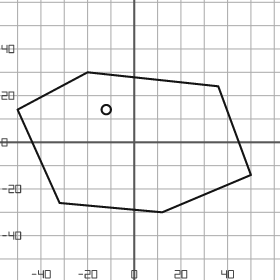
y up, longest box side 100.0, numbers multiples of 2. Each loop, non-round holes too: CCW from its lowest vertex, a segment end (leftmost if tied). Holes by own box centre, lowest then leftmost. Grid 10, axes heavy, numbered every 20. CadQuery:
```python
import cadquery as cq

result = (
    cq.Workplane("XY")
    .moveTo(12.0, -30.0)
    .lineTo(50.0, -14.0)
    .lineTo(36.0, 24.0)
    .lineTo(-20.0, 30.0)
    .lineTo(-50.0, 14.0)
    .lineTo(-32.0, -26.0)
    .close()
    .moveTo(-12.0, 14.0)
    .circle(2.0)
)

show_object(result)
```